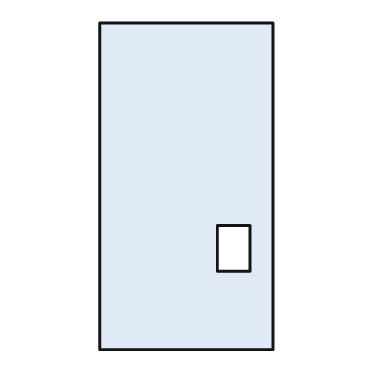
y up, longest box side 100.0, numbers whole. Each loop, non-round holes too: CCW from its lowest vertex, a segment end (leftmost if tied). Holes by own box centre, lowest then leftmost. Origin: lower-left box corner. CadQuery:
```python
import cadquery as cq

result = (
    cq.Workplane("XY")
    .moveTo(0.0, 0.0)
    .lineTo(53.0, 0.0)
    .lineTo(53.0, 100.0)
    .lineTo(0.0, 100.0)
    .close()
    .moveTo(36.0, 24.0)
    .lineTo(46.0, 24.0)
    .lineTo(46.0, 38.0)
    .lineTo(36.0, 38.0)
    .close()
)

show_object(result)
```